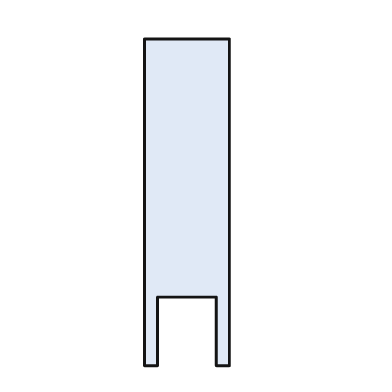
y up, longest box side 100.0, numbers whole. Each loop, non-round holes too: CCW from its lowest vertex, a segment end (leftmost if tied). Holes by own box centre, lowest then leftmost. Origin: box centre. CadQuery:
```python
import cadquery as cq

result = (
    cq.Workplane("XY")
    .moveTo(-13.0, -50.0)
    .lineTo(-9.0, -50.0)
    .lineTo(-9.0, -29.0)
    .lineTo(9.0, -29.0)
    .lineTo(9.0, -50.0)
    .lineTo(13.0, -50.0)
    .lineTo(13.0, 50.0)
    .lineTo(-13.0, 50.0)
    .close()
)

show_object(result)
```